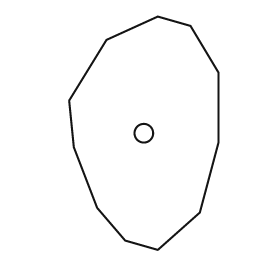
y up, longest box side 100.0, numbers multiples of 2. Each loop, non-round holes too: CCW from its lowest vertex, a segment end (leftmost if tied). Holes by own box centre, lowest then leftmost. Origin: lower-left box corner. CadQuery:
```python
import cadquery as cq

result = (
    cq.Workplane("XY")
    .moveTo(38.0, 0.0)
    .lineTo(56.0, 16.0)
    .lineTo(64.0, 46.0)
    .lineTo(64.0, 76.0)
    .lineTo(52.0, 96.0)
    .lineTo(38.0, 100.0)
    .lineTo(16.0, 90.0)
    .lineTo(0.0, 64.0)
    .lineTo(2.0, 44.0)
    .lineTo(12.0, 18.0)
    .lineTo(24.0, 4.0)
    .close()
    .moveTo(32.0, 50.0)
    .circle(4.0)
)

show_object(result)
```